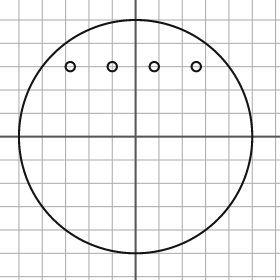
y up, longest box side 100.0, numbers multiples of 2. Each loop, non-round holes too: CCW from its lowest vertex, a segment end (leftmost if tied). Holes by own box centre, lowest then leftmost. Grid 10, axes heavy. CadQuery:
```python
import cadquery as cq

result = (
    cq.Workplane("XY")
    .moveTo(0.0, 0.0)
    .circle(50.0)
    .moveTo(-28.0, 30.0)
    .circle(2.0)
    .moveTo(-10.0, 30.0)
    .circle(2.0)
    .moveTo(8.0, 30.0)
    .circle(2.0)
    .moveTo(26.0, 30.0)
    .circle(2.0)
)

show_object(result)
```